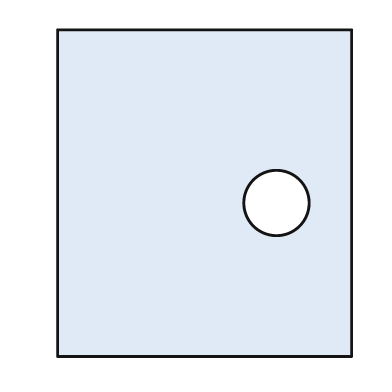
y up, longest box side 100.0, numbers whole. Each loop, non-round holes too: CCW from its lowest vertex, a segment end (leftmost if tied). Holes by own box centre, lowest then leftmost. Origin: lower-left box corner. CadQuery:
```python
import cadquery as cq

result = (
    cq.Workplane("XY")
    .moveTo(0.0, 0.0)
    .lineTo(90.0, 0.0)
    .lineTo(90.0, 100.0)
    .lineTo(0.0, 100.0)
    .close()
    .moveTo(67.0, 47.0)
    .circle(10.0)
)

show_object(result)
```